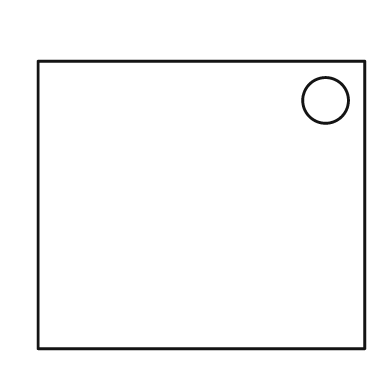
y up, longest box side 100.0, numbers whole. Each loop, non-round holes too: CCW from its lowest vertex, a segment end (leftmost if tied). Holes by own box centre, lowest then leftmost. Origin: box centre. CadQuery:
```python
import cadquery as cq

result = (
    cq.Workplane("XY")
    .moveTo(-50.0, -44.0)
    .lineTo(50.0, -44.0)
    .lineTo(50.0, 44.0)
    .lineTo(-50.0, 44.0)
    .close()
    .moveTo(38.0, 32.0)
    .circle(7.0)
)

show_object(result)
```